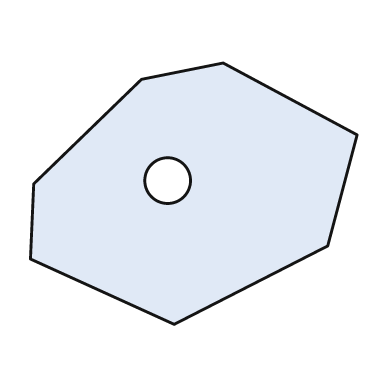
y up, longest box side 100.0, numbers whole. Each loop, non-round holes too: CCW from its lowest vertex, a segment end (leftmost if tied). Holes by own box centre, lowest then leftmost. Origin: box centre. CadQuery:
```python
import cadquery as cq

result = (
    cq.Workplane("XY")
    .moveTo(-6.0, -40.0)
    .lineTo(41.0, -16.0)
    .lineTo(50.0, 18.0)
    .lineTo(9.0, 40.0)
    .lineTo(-16.0, 35.0)
    .lineTo(-49.0, 3.0)
    .lineTo(-50.0, -20.0)
    .close()
    .moveTo(-8.0, 4.0)
    .circle(7.0)
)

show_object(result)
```